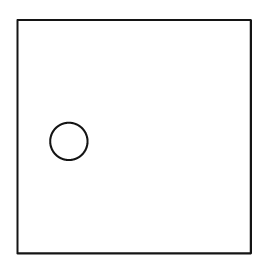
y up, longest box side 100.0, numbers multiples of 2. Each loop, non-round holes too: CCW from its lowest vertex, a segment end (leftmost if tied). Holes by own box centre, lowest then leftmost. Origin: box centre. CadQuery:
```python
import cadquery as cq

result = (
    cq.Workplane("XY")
    .moveTo(-50.0, -50.0)
    .lineTo(50.0, -50.0)
    .lineTo(50.0, 50.0)
    .lineTo(-50.0, 50.0)
    .close()
    .moveTo(-28.0, -2.0)
    .circle(8.0)
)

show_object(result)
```